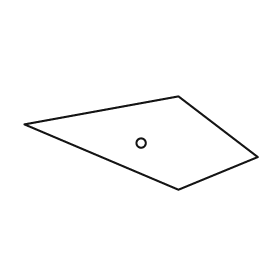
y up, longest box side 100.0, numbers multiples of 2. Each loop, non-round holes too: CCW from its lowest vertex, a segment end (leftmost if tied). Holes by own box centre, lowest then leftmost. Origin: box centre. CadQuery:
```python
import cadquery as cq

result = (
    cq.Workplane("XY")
    .moveTo(16.0, -20.0)
    .lineTo(50.0, -6.0)
    .lineTo(16.0, 20.0)
    .lineTo(-50.0, 8.0)
    .close()
    .moveTo(0.0, 0.0)
    .circle(2.0)
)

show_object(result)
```